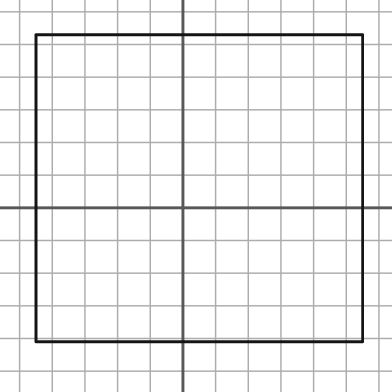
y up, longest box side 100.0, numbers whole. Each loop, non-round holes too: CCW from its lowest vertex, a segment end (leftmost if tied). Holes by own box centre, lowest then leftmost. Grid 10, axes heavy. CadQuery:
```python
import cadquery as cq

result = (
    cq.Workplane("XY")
    .moveTo(-45.0, -41.0)
    .lineTo(55.0, -41.0)
    .lineTo(55.0, 53.0)
    .lineTo(-45.0, 53.0)
    .close()
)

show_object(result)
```